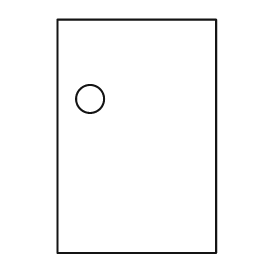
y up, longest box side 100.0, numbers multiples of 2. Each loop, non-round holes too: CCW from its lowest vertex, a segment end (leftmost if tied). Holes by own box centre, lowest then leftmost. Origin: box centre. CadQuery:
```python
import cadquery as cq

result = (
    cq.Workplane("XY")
    .moveTo(-34.0, -50.0)
    .lineTo(34.0, -50.0)
    .lineTo(34.0, 50.0)
    .lineTo(-34.0, 50.0)
    .close()
    .moveTo(-20.0, 16.0)
    .circle(6.0)
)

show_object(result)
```